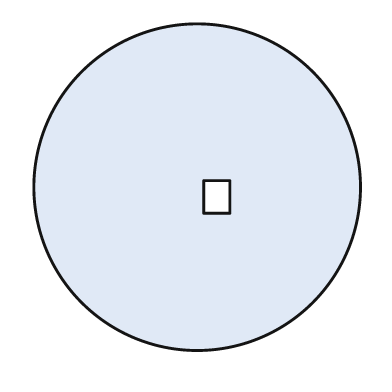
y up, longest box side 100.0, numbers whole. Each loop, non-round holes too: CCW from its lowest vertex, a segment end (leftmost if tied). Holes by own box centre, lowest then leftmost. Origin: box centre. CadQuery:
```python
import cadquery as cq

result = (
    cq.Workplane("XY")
    .moveTo(0.0, 0.0)
    .circle(50.0)
    .moveTo(2.0, -8.0)
    .lineTo(10.0, -8.0)
    .lineTo(10.0, 2.0)
    .lineTo(2.0, 2.0)
    .close()
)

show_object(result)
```